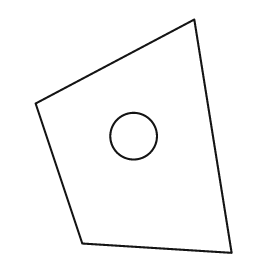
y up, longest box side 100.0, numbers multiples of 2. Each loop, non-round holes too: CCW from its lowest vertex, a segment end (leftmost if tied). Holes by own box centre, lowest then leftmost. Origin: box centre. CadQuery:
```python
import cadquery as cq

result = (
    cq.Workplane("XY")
    .moveTo(42.0, -50.0)
    .lineTo(26.0, 50.0)
    .lineTo(-42.0, 14.0)
    .lineTo(-22.0, -46.0)
    .close()
    .moveTo(0.0, 0.0)
    .circle(10.0)
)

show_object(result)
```